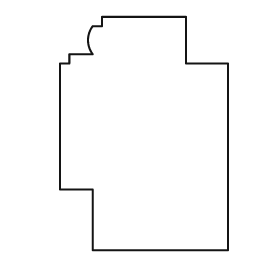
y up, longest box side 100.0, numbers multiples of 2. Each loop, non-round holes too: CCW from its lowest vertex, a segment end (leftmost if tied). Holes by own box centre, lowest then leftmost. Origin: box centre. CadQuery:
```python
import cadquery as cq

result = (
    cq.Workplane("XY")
    .moveTo(-22.0, -50.0)
    .lineTo(36.0, -50.0)
    .lineTo(36.0, 30.0)
    .lineTo(18.0, 30.0)
    .lineTo(18.0, 50.0)
    .lineTo(-18.0, 50.0)
    .lineTo(-18.0, 46.0)
    .lineTo(-22.0, 46.0)
    .threePointArc((-24.0, 40.0), (-22.0, 34.0))
    .lineTo(-32.0, 34.0)
    .lineTo(-32.0, 30.0)
    .lineTo(-36.0, 30.0)
    .lineTo(-36.0, -24.0)
    .lineTo(-22.0, -24.0)
    .close()
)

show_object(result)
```